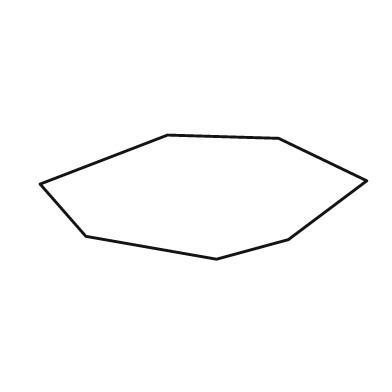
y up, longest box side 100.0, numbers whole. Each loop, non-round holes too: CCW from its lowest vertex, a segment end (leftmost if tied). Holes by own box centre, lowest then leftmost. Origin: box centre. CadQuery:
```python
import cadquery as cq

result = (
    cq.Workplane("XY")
    .moveTo(4.0, -19.0)
    .lineTo(26.0, -13.0)
    .lineTo(50.0, 5.0)
    .lineTo(23.0, 18.0)
    .lineTo(-11.0, 19.0)
    .lineTo(-50.0, 4.0)
    .lineTo(-36.0, -12.0)
    .close()
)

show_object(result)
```